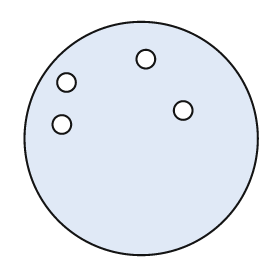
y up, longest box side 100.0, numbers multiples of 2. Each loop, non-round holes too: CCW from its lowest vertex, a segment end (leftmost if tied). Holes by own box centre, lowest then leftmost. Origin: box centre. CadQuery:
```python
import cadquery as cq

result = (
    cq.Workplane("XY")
    .moveTo(0.0, 0.0)
    .circle(50.0)
    .moveTo(-34.0, 6.0)
    .circle(4.0)
    .moveTo(18.0, 12.0)
    .circle(4.0)
    .moveTo(-32.0, 24.0)
    .circle(4.0)
    .moveTo(2.0, 34.0)
    .circle(4.0)
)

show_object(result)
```